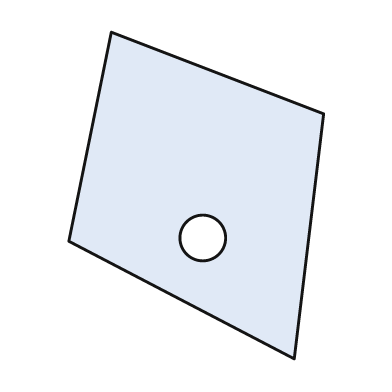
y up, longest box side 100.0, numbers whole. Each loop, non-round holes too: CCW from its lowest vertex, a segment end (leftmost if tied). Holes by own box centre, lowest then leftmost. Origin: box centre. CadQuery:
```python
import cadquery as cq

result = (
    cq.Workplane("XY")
    .moveTo(30.0, -50.0)
    .lineTo(39.0, 25.0)
    .lineTo(-26.0, 50.0)
    .lineTo(-39.0, -14.0)
    .close()
    .moveTo(2.0, -13.0)
    .circle(7.0)
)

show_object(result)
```